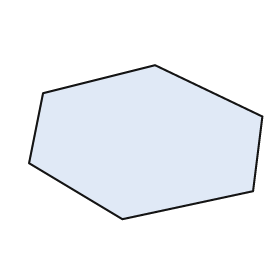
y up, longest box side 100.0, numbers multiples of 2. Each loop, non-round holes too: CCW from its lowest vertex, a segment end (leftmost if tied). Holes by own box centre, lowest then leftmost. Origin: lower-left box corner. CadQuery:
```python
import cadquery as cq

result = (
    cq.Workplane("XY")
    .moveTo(40.0, 0.0)
    .lineTo(96.0, 12.0)
    .lineTo(100.0, 44.0)
    .lineTo(54.0, 66.0)
    .lineTo(6.0, 54.0)
    .lineTo(0.0, 24.0)
    .close()
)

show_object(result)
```